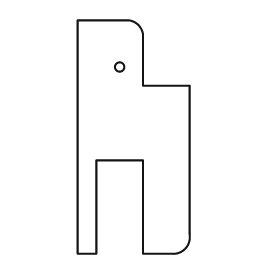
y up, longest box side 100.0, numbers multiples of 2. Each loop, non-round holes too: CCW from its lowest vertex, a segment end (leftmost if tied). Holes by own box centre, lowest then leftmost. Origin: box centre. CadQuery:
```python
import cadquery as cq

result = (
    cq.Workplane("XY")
    .moveTo(-24.0, -50.0)
    .lineTo(-16.0, -50.0)
    .lineTo(-16.0, -10.0)
    .lineTo(4.0, -10.0)
    .lineTo(4.0, -50.0)
    .lineTo(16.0, -50.0)
    .threePointArc((22.0, -48.0), (24.0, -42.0))
    .lineTo(24.0, 22.0)
    .lineTo(4.0, 22.0)
    .lineTo(4.0, 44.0)
    .threePointArc((2.0, 48.0), (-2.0, 50.0))
    .lineTo(-24.0, 50.0)
    .close()
    .moveTo(-6.0, 30.0)
    .circle(2.0)
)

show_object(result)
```